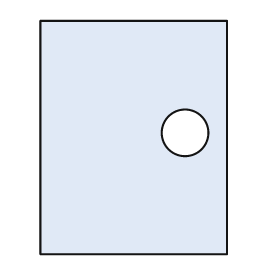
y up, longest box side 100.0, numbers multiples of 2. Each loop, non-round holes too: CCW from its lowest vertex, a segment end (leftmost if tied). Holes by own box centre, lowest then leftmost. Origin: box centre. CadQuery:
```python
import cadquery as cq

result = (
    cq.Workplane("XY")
    .moveTo(-40.0, -50.0)
    .lineTo(40.0, -50.0)
    .lineTo(40.0, 50.0)
    .lineTo(-40.0, 50.0)
    .close()
    .moveTo(22.0, 2.0)
    .circle(10.0)
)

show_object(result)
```